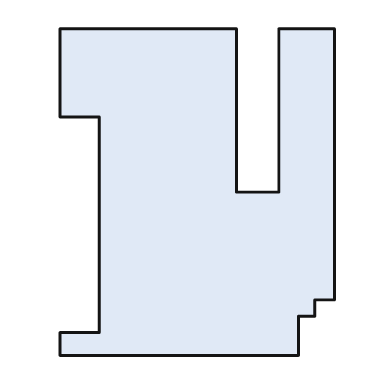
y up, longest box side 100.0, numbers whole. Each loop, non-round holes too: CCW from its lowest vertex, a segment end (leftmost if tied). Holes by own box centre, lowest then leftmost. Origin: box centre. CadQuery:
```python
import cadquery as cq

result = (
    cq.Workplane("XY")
    .moveTo(-42.0, -50.0)
    .lineTo(31.0, -50.0)
    .lineTo(31.0, -38.0)
    .lineTo(36.0, -38.0)
    .lineTo(36.0, -33.0)
    .lineTo(42.0, -33.0)
    .lineTo(42.0, 50.0)
    .lineTo(25.0, 50.0)
    .lineTo(25.0, 0.0)
    .lineTo(12.0, 0.0)
    .lineTo(12.0, 50.0)
    .lineTo(-42.0, 50.0)
    .lineTo(-42.0, 23.0)
    .lineTo(-30.0, 23.0)
    .lineTo(-30.0, -43.0)
    .lineTo(-42.0, -43.0)
    .close()
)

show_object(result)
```